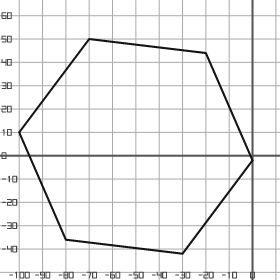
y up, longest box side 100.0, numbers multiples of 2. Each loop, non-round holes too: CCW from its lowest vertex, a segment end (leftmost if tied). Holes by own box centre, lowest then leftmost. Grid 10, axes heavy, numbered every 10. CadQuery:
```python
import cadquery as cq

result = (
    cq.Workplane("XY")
    .moveTo(-30.0, -42.0)
    .lineTo(0.0, -2.0)
    .lineTo(-20.0, 44.0)
    .lineTo(-70.0, 50.0)
    .lineTo(-100.0, 10.0)
    .lineTo(-80.0, -36.0)
    .close()
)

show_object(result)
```